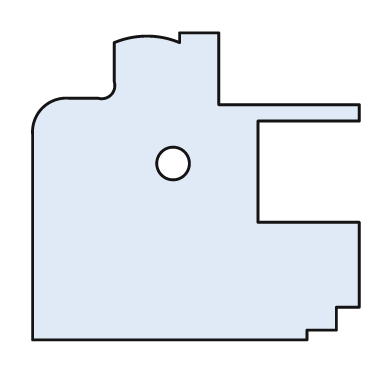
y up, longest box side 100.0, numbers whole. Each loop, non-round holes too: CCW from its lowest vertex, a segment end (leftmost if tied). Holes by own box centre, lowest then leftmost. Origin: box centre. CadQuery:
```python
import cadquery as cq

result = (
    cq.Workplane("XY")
    .moveTo(-50.0, -47.0)
    .lineTo(34.0, -47.0)
    .lineTo(34.0, -44.0)
    .lineTo(43.0, -44.0)
    .lineTo(43.0, -37.0)
    .lineTo(50.0, -37.0)
    .lineTo(50.0, -11.0)
    .lineTo(19.0, -11.0)
    .lineTo(19.0, 20.0)
    .lineTo(50.0, 20.0)
    .lineTo(50.0, 25.0)
    .lineTo(7.0, 25.0)
    .lineTo(7.0, 47.0)
    .lineTo(-5.0, 47.0)
    .lineTo(-5.0, 44.0)
    .threePointArc((-15.0, 46.0), (-25.0, 44.0))
    .lineTo(-25.0, 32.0)
    .threePointArc((-26.0, 28.0), (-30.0, 27.0))
    .lineTo(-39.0, 27.0)
    .threePointArc((-47.0, 24.0), (-50.0, 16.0))
    .close()
    .moveTo(-7.0, 7.0)
    .circle(5.0)
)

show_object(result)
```